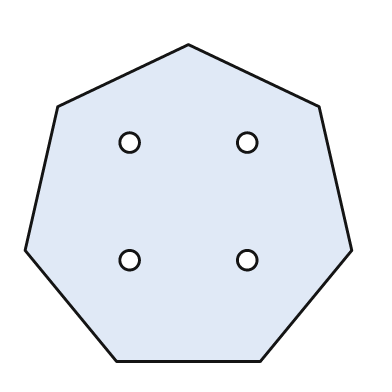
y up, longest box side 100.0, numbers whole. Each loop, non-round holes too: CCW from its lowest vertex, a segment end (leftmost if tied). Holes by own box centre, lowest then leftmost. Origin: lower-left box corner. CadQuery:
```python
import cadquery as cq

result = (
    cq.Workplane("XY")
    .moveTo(28.0, 0.0)
    .lineTo(72.0, 0.0)
    .lineTo(100.0, 34.0)
    .lineTo(90.0, 78.0)
    .lineTo(50.0, 97.0)
    .lineTo(10.0, 78.0)
    .lineTo(0.0, 34.0)
    .close()
    .moveTo(32.0, 31.0)
    .circle(3.0)
    .moveTo(68.0, 31.0)
    .circle(3.0)
    .moveTo(32.0, 67.0)
    .circle(3.0)
    .moveTo(68.0, 67.0)
    .circle(3.0)
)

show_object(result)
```